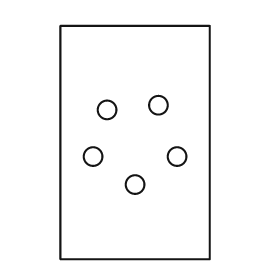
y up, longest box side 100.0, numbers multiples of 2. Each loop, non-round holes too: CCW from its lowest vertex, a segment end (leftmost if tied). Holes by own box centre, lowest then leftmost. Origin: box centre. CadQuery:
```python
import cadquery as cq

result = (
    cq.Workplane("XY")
    .moveTo(-32.0, -50.0)
    .lineTo(32.0, -50.0)
    .lineTo(32.0, 50.0)
    .lineTo(-32.0, 50.0)
    .close()
    .moveTo(0.0, -18.0)
    .circle(4.0)
    .moveTo(-18.0, -6.0)
    .circle(4.0)
    .moveTo(18.0, -6.0)
    .circle(4.0)
    .moveTo(-12.0, 14.0)
    .circle(4.0)
    .moveTo(10.0, 16.0)
    .circle(4.0)
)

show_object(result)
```